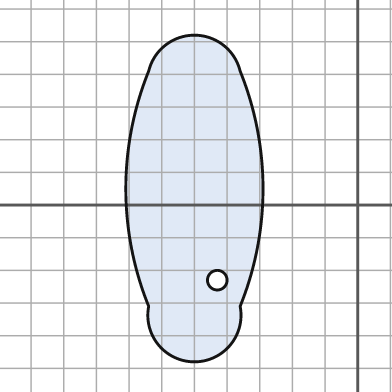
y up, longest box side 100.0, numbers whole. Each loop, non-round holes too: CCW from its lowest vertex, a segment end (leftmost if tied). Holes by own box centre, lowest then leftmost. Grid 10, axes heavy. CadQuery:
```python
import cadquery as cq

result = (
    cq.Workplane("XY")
    .moveTo(-64.0, -31.0)
    .threePointArc((-50.0, -48.0), (-36.0, -31.0))
    .threePointArc((-29.0, 5.0), (-36.0, 41.0))
    .threePointArc((-50.0, 52.0), (-64.0, 41.0))
    .threePointArc((-71.0, 5.0), (-64.0, -31.0))
    .close()
    .moveTo(-43.0, -23.0)
    .circle(3.0)
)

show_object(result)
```